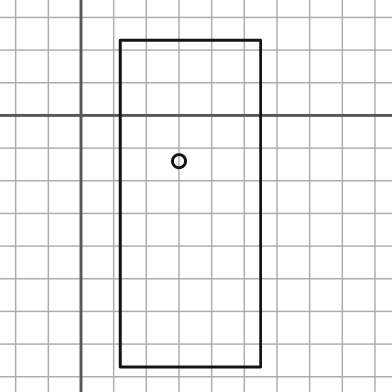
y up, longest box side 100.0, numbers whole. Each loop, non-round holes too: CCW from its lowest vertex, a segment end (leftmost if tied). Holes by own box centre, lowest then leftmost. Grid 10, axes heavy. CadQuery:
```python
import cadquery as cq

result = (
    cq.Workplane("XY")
    .moveTo(12.0, -77.0)
    .lineTo(55.0, -77.0)
    .lineTo(55.0, 23.0)
    .lineTo(12.0, 23.0)
    .close()
    .moveTo(30.0, -14.0)
    .circle(2.0)
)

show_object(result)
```